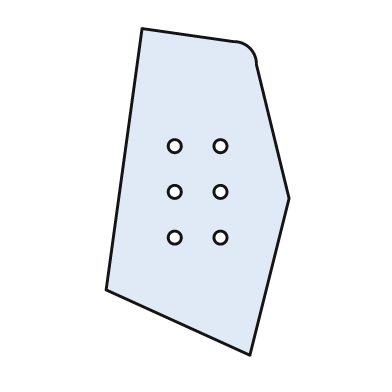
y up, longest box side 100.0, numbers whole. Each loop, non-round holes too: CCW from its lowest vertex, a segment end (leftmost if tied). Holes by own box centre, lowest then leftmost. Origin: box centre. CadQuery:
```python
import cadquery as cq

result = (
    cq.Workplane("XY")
    .moveTo(16.0, -50.0)
    .lineTo(28.0, -2.0)
    .lineTo(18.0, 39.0)
    .threePointArc((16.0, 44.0), (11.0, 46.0))
    .lineTo(-17.0, 50.0)
    .lineTo(-28.0, -30.0)
    .close()
    .moveTo(-7.0, -14.0)
    .circle(2.0)
    .moveTo(7.0, -14.0)
    .circle(2.0)
    .moveTo(-7.0, 0.0)
    .circle(2.0)
    .moveTo(7.0, 0.0)
    .circle(2.0)
    .moveTo(-7.0, 14.0)
    .circle(2.0)
    .moveTo(7.0, 14.0)
    .circle(2.0)
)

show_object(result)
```